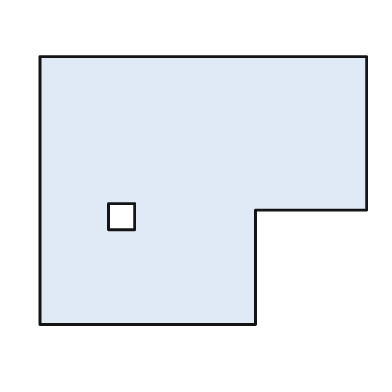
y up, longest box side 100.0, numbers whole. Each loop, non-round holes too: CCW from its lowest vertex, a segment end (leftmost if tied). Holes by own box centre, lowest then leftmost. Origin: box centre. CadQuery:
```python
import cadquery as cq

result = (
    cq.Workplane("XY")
    .moveTo(-50.0, -41.0)
    .lineTo(16.0, -41.0)
    .lineTo(16.0, -6.0)
    .lineTo(50.0, -6.0)
    .lineTo(50.0, 41.0)
    .lineTo(-50.0, 41.0)
    .close()
    .moveTo(-29.0, -12.0)
    .lineTo(-21.0, -12.0)
    .lineTo(-21.0, -4.0)
    .lineTo(-29.0, -4.0)
    .close()
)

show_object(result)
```